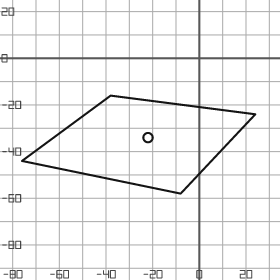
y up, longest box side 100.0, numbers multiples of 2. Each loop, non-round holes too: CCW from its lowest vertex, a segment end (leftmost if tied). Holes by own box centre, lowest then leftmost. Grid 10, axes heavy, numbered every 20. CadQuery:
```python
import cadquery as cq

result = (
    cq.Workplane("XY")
    .moveTo(-8.0, -58.0)
    .lineTo(24.0, -24.0)
    .lineTo(-38.0, -16.0)
    .lineTo(-76.0, -44.0)
    .close()
    .moveTo(-22.0, -34.0)
    .circle(2.0)
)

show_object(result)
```